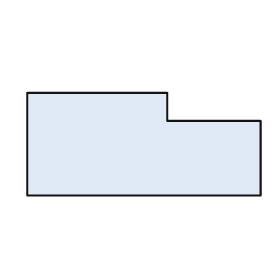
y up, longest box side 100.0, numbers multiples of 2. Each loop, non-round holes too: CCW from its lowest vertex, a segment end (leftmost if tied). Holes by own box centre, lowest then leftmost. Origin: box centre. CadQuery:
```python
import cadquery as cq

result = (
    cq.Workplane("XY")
    .moveTo(-50.0, -22.0)
    .lineTo(50.0, -22.0)
    .lineTo(50.0, 10.0)
    .lineTo(10.0, 10.0)
    .lineTo(10.0, 22.0)
    .lineTo(-50.0, 22.0)
    .close()
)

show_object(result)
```